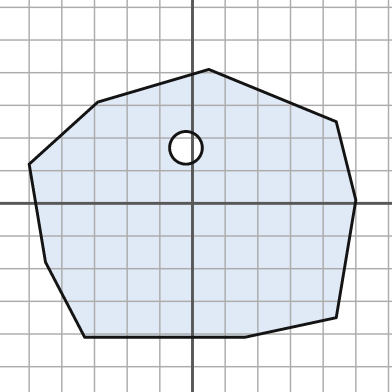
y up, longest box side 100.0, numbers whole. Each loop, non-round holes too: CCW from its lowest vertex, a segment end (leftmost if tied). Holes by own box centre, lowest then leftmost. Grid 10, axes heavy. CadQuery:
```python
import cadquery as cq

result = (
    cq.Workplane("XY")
    .moveTo(-33.0, -41.0)
    .lineTo(16.0, -41.0)
    .lineTo(44.0, -35.0)
    .lineTo(50.0, 1.0)
    .lineTo(44.0, 25.0)
    .lineTo(5.0, 41.0)
    .lineTo(-29.0, 31.0)
    .lineTo(-50.0, 12.0)
    .lineTo(-45.0, -18.0)
    .close()
    .moveTo(-2.0, 17.0)
    .circle(5.0)
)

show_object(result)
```